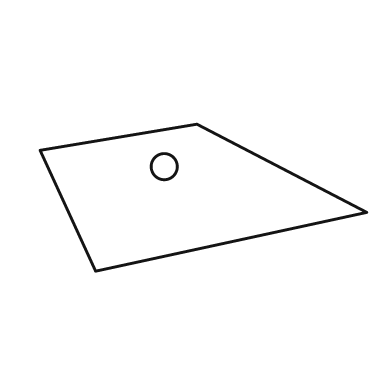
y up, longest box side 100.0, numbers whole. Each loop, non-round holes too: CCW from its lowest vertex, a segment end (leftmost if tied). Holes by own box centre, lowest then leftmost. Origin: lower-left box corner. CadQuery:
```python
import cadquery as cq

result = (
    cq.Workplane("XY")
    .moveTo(17.0, 0.0)
    .lineTo(100.0, 18.0)
    .lineTo(48.0, 45.0)
    .lineTo(0.0, 37.0)
    .close()
    .moveTo(38.0, 32.0)
    .circle(4.0)
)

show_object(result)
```